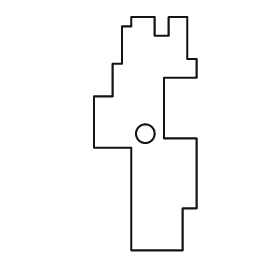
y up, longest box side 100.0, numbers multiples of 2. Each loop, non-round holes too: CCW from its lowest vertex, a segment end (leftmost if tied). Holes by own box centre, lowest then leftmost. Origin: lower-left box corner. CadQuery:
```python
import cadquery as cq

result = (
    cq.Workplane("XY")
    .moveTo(16.0, 0.0)
    .lineTo(38.0, 0.0)
    .lineTo(38.0, 18.0)
    .lineTo(44.0, 18.0)
    .lineTo(44.0, 48.0)
    .lineTo(30.0, 48.0)
    .lineTo(30.0, 74.0)
    .lineTo(44.0, 74.0)
    .lineTo(44.0, 82.0)
    .lineTo(40.0, 82.0)
    .lineTo(40.0, 100.0)
    .lineTo(32.0, 100.0)
    .lineTo(32.0, 92.0)
    .lineTo(26.0, 92.0)
    .lineTo(26.0, 100.0)
    .lineTo(16.0, 100.0)
    .lineTo(16.0, 96.0)
    .lineTo(12.0, 96.0)
    .lineTo(12.0, 80.0)
    .lineTo(8.0, 80.0)
    .lineTo(8.0, 66.0)
    .lineTo(0.0, 66.0)
    .lineTo(0.0, 44.0)
    .lineTo(16.0, 44.0)
    .close()
    .moveTo(22.0, 50.0)
    .circle(4.0)
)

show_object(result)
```